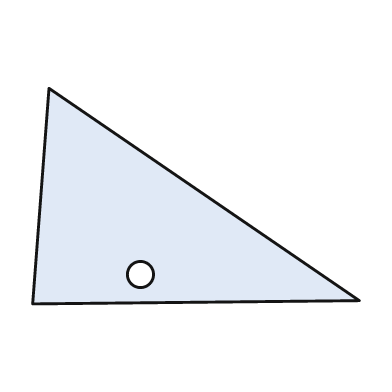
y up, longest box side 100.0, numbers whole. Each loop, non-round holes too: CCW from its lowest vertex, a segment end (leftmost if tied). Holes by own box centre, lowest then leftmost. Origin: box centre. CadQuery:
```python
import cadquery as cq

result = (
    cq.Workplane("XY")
    .moveTo(-50.0, -33.0)
    .lineTo(50.0, -32.0)
    .lineTo(-45.0, 33.0)
    .close()
    .moveTo(-17.0, -24.0)
    .circle(4.0)
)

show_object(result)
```